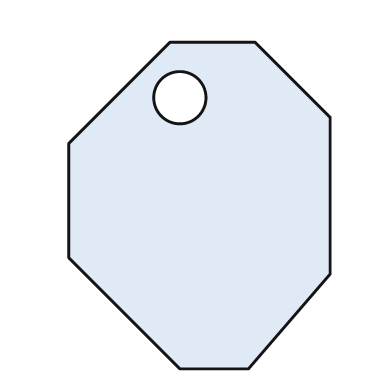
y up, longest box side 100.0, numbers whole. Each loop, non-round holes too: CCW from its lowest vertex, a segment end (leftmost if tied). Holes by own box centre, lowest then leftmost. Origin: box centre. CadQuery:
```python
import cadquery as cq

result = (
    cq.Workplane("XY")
    .moveTo(-6.0, -50.0)
    .lineTo(15.0, -50.0)
    .lineTo(40.0, -21.0)
    .lineTo(40.0, 27.0)
    .lineTo(17.0, 50.0)
    .lineTo(-9.0, 50.0)
    .lineTo(-40.0, 19.0)
    .lineTo(-40.0, -16.0)
    .close()
    .moveTo(-6.0, 33.0)
    .circle(8.0)
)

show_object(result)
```